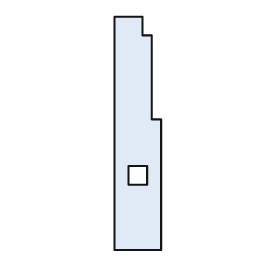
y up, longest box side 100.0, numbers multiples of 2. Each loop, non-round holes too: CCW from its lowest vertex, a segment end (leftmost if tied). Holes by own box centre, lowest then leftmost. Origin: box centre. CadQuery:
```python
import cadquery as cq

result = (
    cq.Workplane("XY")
    .moveTo(-10.0, -50.0)
    .lineTo(10.0, -50.0)
    .lineTo(10.0, 6.0)
    .lineTo(6.0, 6.0)
    .lineTo(6.0, 42.0)
    .lineTo(2.0, 42.0)
    .lineTo(2.0, 50.0)
    .lineTo(-10.0, 50.0)
    .close()
    .moveTo(-4.0, -22.0)
    .lineTo(4.0, -22.0)
    .lineTo(4.0, -14.0)
    .lineTo(-4.0, -14.0)
    .close()
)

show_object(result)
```